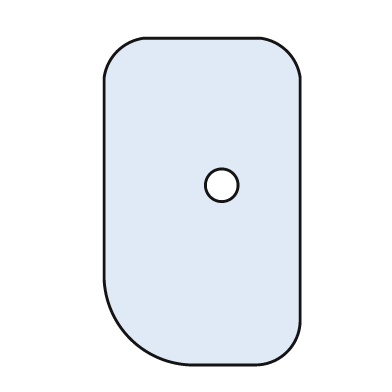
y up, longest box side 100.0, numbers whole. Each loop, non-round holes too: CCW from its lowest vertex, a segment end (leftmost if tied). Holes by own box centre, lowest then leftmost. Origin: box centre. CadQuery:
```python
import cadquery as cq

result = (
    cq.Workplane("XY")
    .moveTo(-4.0, -50.0)
    .lineTo(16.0, -50.0)
    .threePointArc((26.0, -46.0), (30.0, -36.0))
    .lineTo(30.0, 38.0)
    .threePointArc((26.0, 46.0), (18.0, 50.0))
    .lineTo(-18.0, 50.0)
    .threePointArc((-26.0, 46.0), (-30.0, 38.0))
    .lineTo(-30.0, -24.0)
    .threePointArc((-22.0, -42.0), (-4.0, -50.0))
    .close()
    .moveTo(6.0, 5.0)
    .circle(5.0)
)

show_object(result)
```